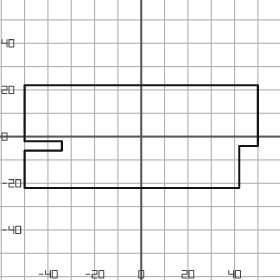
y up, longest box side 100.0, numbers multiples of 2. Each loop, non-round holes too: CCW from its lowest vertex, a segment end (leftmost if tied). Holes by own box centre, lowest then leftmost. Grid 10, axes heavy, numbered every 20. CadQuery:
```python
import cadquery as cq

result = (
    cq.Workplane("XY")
    .moveTo(-50.0, -22.0)
    .lineTo(42.0, -22.0)
    .lineTo(42.0, -4.0)
    .lineTo(50.0, -4.0)
    .lineTo(50.0, 22.0)
    .lineTo(-50.0, 22.0)
    .lineTo(-50.0, -2.0)
    .lineTo(-34.0, -2.0)
    .lineTo(-34.0, -6.0)
    .lineTo(-50.0, -6.0)
    .close()
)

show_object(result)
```